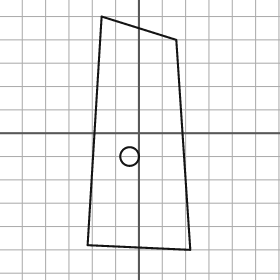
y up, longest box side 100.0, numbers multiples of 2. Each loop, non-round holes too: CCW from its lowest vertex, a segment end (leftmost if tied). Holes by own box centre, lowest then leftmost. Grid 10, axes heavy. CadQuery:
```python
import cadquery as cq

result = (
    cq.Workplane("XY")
    .moveTo(22.0, -50.0)
    .lineTo(16.0, 40.0)
    .lineTo(-16.0, 50.0)
    .lineTo(-22.0, -48.0)
    .close()
    .moveTo(-4.0, -10.0)
    .circle(4.0)
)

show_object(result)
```